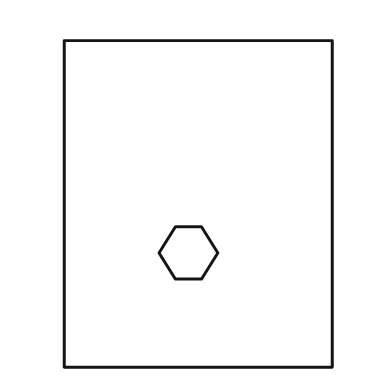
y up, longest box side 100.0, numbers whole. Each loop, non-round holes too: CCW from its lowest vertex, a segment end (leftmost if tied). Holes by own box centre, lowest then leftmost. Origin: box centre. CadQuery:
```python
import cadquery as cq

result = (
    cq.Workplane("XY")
    .moveTo(-41.0, -50.0)
    .lineTo(41.0, -50.0)
    .lineTo(41.0, 50.0)
    .lineTo(-41.0, 50.0)
    .close()
    .moveTo(-7.0, -23.0)
    .lineTo(1.0, -23.0)
    .lineTo(6.0, -15.0)
    .lineTo(1.0, -7.0)
    .lineTo(-7.0, -7.0)
    .lineTo(-12.0, -15.0)
    .close()
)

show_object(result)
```